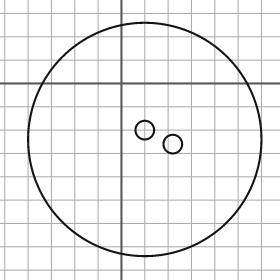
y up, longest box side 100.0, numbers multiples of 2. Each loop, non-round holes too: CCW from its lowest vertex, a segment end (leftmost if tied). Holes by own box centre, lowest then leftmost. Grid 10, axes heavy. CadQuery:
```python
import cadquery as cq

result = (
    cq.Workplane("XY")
    .moveTo(10.0, -24.0)
    .circle(50.0)
    .moveTo(22.0, -26.0)
    .circle(4.0)
    .moveTo(10.0, -20.0)
    .circle(4.0)
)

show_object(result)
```